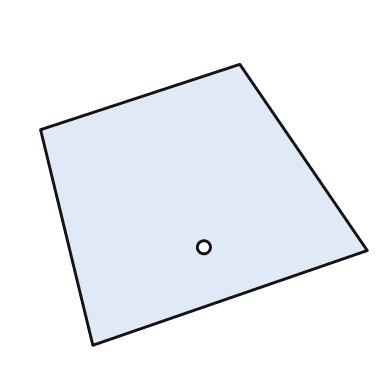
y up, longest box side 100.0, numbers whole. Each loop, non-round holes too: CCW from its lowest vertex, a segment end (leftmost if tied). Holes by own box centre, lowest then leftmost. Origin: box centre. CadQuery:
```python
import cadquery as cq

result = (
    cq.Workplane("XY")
    .moveTo(-34.0, -43.0)
    .lineTo(50.0, -14.0)
    .lineTo(11.0, 43.0)
    .lineTo(-50.0, 23.0)
    .close()
    .moveTo(0.0, -13.0)
    .circle(2.0)
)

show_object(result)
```